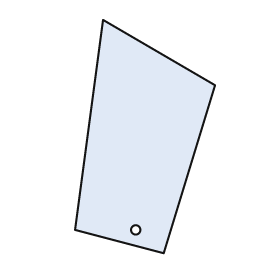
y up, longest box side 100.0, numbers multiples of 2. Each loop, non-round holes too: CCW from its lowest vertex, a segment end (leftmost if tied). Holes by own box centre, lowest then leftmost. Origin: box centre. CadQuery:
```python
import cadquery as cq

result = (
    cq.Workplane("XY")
    .moveTo(8.0, -50.0)
    .lineTo(30.0, 22.0)
    .lineTo(-18.0, 50.0)
    .lineTo(-30.0, -40.0)
    .close()
    .moveTo(-4.0, -40.0)
    .circle(2.0)
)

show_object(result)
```